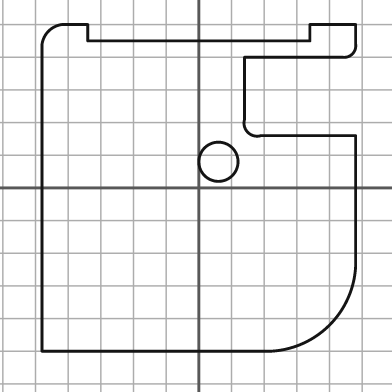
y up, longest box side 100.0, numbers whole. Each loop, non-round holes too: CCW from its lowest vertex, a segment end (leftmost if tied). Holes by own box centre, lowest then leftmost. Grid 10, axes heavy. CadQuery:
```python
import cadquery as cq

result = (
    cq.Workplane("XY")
    .moveTo(-48.0, -50.0)
    .lineTo(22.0, -50.0)
    .threePointArc((40.0, -42.0), (48.0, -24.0))
    .lineTo(48.0, 16.0)
    .lineTo(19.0, 16.0)
    .threePointArc((15.0, 17.0), (14.0, 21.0))
    .lineTo(14.0, 40.0)
    .lineTo(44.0, 40.0)
    .threePointArc((47.0, 41.0), (48.0, 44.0))
    .lineTo(48.0, 50.0)
    .lineTo(34.0, 50.0)
    .lineTo(34.0, 45.0)
    .lineTo(-34.0, 45.0)
    .lineTo(-34.0, 50.0)
    .lineTo(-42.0, 50.0)
    .threePointArc((-46.0, 48.0), (-48.0, 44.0))
    .close()
    .moveTo(6.0, 8.0)
    .circle(6.0)
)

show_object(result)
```